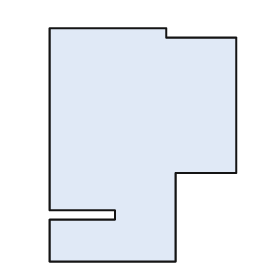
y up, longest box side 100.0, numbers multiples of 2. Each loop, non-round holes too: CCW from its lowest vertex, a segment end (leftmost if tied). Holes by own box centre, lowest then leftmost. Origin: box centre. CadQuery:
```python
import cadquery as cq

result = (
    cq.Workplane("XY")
    .moveTo(-40.0, -50.0)
    .lineTo(14.0, -50.0)
    .lineTo(14.0, -12.0)
    .lineTo(40.0, -12.0)
    .lineTo(40.0, 46.0)
    .lineTo(10.0, 46.0)
    .lineTo(10.0, 50.0)
    .lineTo(-40.0, 50.0)
    .lineTo(-40.0, -28.0)
    .lineTo(-12.0, -28.0)
    .lineTo(-12.0, -32.0)
    .lineTo(-40.0, -32.0)
    .close()
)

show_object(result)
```